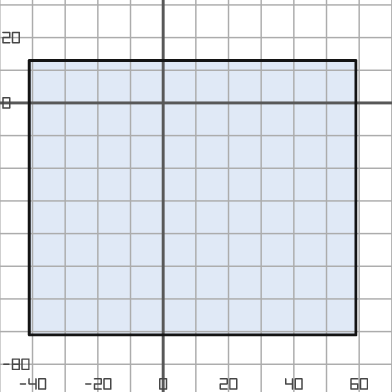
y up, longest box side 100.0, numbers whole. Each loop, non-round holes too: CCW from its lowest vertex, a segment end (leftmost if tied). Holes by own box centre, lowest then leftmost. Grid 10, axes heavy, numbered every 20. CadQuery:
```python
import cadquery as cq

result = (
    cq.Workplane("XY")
    .moveTo(-41.0, -71.0)
    .lineTo(59.0, -71.0)
    .lineTo(59.0, 13.0)
    .lineTo(-41.0, 13.0)
    .close()
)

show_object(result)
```